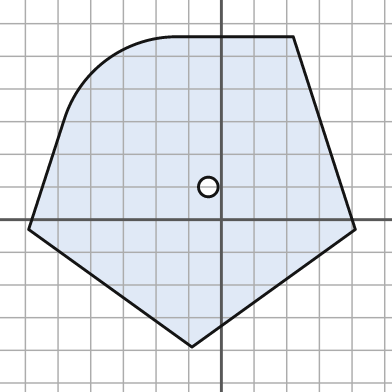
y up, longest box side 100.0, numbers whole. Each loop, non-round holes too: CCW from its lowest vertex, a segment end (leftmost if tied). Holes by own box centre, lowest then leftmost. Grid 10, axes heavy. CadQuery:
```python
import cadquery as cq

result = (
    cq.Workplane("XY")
    .moveTo(-9.0, -39.0)
    .lineTo(41.0, -3.0)
    .lineTo(22.0, 56.0)
    .lineTo(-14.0, 56.0)
    .threePointArc((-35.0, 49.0), (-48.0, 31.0))
    .lineTo(-59.0, -3.0)
    .close()
    .moveTo(-4.0, 10.0)
    .circle(3.0)
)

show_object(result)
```